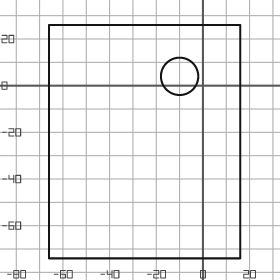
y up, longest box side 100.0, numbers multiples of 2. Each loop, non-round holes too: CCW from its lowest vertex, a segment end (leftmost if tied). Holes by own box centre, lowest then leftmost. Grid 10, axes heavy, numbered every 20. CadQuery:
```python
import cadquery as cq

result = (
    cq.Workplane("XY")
    .moveTo(-66.0, -74.0)
    .lineTo(16.0, -74.0)
    .lineTo(16.0, 26.0)
    .lineTo(-66.0, 26.0)
    .close()
    .moveTo(-10.0, 4.0)
    .circle(8.0)
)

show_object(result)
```